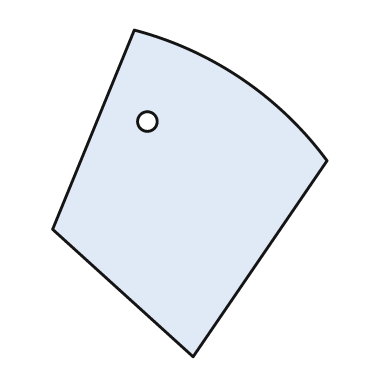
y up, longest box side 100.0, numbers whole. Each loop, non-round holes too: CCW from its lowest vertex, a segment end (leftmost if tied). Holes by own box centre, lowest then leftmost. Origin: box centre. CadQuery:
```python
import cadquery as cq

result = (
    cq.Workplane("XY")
    .moveTo(1.0, -50.0)
    .lineTo(42.0, 10.0)
    .threePointArc((16.0, 35.0), (-17.0, 50.0))
    .lineTo(-42.0, -11.0)
    .close()
    .moveTo(-13.0, 22.0)
    .circle(3.0)
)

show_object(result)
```